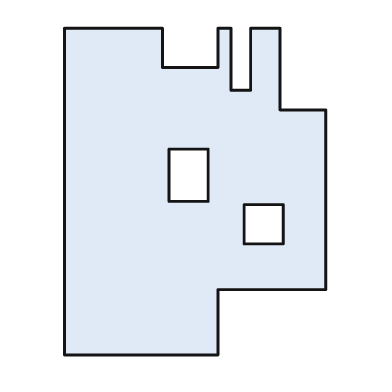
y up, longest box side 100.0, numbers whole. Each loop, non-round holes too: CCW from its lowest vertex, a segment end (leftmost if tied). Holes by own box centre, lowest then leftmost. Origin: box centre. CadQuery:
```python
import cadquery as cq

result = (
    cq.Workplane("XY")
    .moveTo(-40.0, -50.0)
    .lineTo(7.0, -50.0)
    .lineTo(7.0, -30.0)
    .lineTo(40.0, -30.0)
    .lineTo(40.0, 25.0)
    .lineTo(26.0, 25.0)
    .lineTo(26.0, 50.0)
    .lineTo(17.0, 50.0)
    .lineTo(17.0, 31.0)
    .lineTo(11.0, 31.0)
    .lineTo(11.0, 50.0)
    .lineTo(7.0, 50.0)
    .lineTo(7.0, 38.0)
    .lineTo(-10.0, 38.0)
    .lineTo(-10.0, 50.0)
    .lineTo(-40.0, 50.0)
    .close()
    .moveTo(15.0, -16.0)
    .lineTo(27.0, -16.0)
    .lineTo(27.0, -4.0)
    .lineTo(15.0, -4.0)
    .close()
    .moveTo(-8.0, -3.0)
    .lineTo(4.0, -3.0)
    .lineTo(4.0, 13.0)
    .lineTo(-8.0, 13.0)
    .close()
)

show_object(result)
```